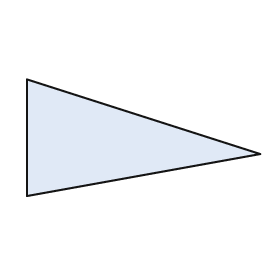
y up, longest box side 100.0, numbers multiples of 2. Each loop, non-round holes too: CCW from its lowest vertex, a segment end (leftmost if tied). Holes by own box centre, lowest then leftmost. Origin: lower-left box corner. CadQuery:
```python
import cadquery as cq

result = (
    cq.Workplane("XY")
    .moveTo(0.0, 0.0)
    .lineTo(100.0, 18.0)
    .lineTo(0.0, 50.0)
    .close()
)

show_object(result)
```